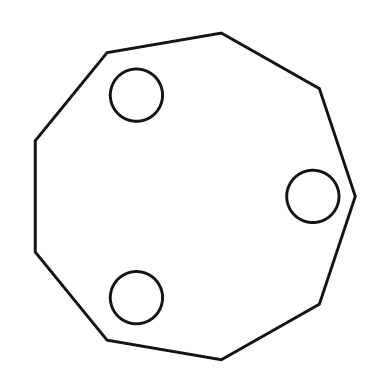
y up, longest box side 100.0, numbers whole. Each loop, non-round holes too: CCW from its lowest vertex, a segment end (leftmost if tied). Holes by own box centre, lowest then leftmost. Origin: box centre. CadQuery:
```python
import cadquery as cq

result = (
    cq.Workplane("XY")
    .moveTo(8.0, -50.0)
    .lineTo(38.0, -33.0)
    .lineTo(49.0, 0.0)
    .lineTo(38.0, 33.0)
    .lineTo(8.0, 50.0)
    .lineTo(-27.0, 44.0)
    .lineTo(-49.0, 17.0)
    .lineTo(-49.0, -17.0)
    .lineTo(-27.0, -44.0)
    .close()
    .moveTo(-18.0, -31.0)
    .circle(8.0)
    .moveTo(36.0, 0.0)
    .circle(8.0)
    .moveTo(-18.0, 31.0)
    .circle(8.0)
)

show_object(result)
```